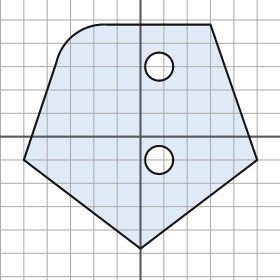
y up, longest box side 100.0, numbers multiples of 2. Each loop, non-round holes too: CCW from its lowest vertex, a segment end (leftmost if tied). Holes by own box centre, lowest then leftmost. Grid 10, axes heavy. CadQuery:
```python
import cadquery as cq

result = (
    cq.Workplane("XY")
    .moveTo(0.0, -48.0)
    .lineTo(50.0, -10.0)
    .lineTo(30.0, 48.0)
    .lineTo(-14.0, 48.0)
    .threePointArc((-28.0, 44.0), (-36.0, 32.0))
    .lineTo(-50.0, -10.0)
    .close()
    .moveTo(8.0, -10.0)
    .circle(6.0)
    .moveTo(8.0, 30.0)
    .circle(6.0)
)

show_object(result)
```